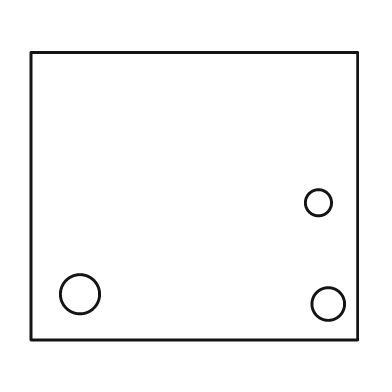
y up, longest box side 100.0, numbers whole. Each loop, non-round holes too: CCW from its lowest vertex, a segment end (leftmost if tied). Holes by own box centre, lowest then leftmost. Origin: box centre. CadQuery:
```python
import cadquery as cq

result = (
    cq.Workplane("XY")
    .moveTo(-50.0, -44.0)
    .lineTo(50.0, -44.0)
    .lineTo(50.0, 44.0)
    .lineTo(-50.0, 44.0)
    .close()
    .moveTo(41.0, -33.0)
    .circle(5.0)
    .moveTo(-35.0, -30.0)
    .circle(6.0)
    .moveTo(38.0, -2.0)
    .circle(4.0)
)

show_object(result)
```